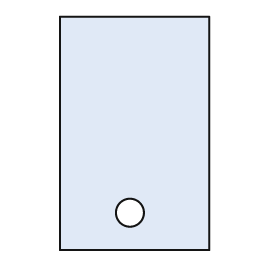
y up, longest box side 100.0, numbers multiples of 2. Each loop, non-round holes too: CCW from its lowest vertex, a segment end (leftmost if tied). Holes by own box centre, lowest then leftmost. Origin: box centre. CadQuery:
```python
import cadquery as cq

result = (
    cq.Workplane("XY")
    .moveTo(-32.0, -50.0)
    .lineTo(32.0, -50.0)
    .lineTo(32.0, 50.0)
    .lineTo(-32.0, 50.0)
    .close()
    .moveTo(-2.0, -34.0)
    .circle(6.0)
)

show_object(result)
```